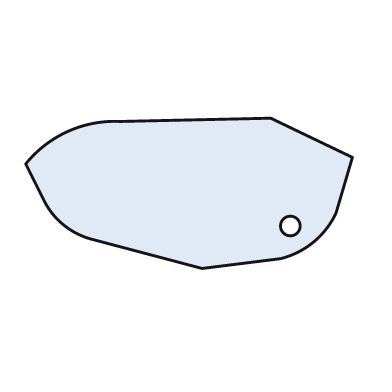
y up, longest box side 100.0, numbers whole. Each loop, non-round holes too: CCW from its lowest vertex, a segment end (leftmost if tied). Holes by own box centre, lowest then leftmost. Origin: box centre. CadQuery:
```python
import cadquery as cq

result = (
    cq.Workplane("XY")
    .moveTo(4.0, -23.0)
    .lineTo(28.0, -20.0)
    .threePointArc((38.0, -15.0), (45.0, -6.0))
    .lineTo(50.0, 11.0)
    .lineTo(25.0, 23.0)
    .lineTo(-21.0, 22.0)
    .threePointArc((-37.0, 19.0), (-50.0, 9.0))
    .lineTo(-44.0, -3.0)
    .threePointArc((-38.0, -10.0), (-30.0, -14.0))
    .close()
    .moveTo(31.0, -10.0)
    .circle(3.0)
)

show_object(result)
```